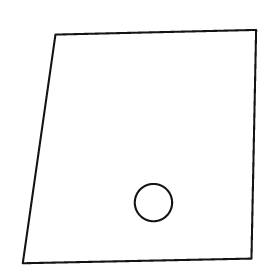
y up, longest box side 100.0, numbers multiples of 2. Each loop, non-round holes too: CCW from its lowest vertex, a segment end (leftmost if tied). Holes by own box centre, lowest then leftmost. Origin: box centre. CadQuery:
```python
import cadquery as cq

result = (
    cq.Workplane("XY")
    .moveTo(-50.0, -50.0)
    .lineTo(48.0, -48.0)
    .lineTo(50.0, 50.0)
    .lineTo(-36.0, 48.0)
    .close()
    .moveTo(6.0, -24.0)
    .circle(8.0)
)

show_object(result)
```